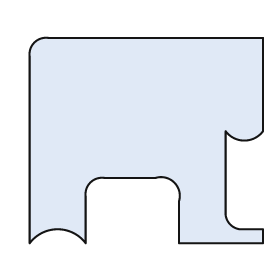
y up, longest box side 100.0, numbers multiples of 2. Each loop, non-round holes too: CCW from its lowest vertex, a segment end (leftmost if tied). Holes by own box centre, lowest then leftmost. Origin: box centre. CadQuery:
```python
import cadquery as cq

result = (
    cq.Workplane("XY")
    .moveTo(-50.0, -44.0)
    .threePointArc((-38.0, -38.0), (-26.0, -44.0))
    .lineTo(-26.0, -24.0)
    .threePointArc((-24.0, -18.0), (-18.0, -16.0))
    .lineTo(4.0, -16.0)
    .threePointArc((12.0, -18.0), (14.0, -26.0))
    .lineTo(14.0, -44.0)
    .lineTo(50.0, -44.0)
    .lineTo(50.0, -38.0)
    .lineTo(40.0, -38.0)
    .threePointArc((36.0, -36.0), (34.0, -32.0))
    .lineTo(34.0, 4.0)
    .threePointArc((42.0, 0.0), (50.0, 4.0))
    .lineTo(50.0, 44.0)
    .lineTo(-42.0, 44.0)
    .threePointArc((-48.0, 42.0), (-50.0, 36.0))
    .close()
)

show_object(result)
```